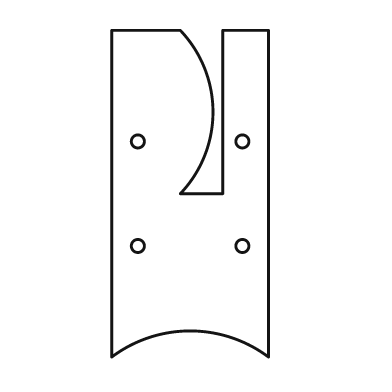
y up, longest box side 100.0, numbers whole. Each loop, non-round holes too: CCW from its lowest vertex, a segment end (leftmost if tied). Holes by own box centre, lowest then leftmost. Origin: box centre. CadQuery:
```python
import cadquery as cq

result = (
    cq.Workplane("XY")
    .moveTo(-24.0, -50.0)
    .threePointArc((0.0, -42.0), (24.0, -50.0))
    .lineTo(24.0, 50.0)
    .lineTo(10.0, 50.0)
    .lineTo(10.0, 0.0)
    .lineTo(-3.0, 0.0)
    .threePointArc((7.0, 25.0), (-3.0, 50.0))
    .lineTo(-24.0, 50.0)
    .close()
    .moveTo(-16.0, -16.0)
    .circle(2.0)
    .moveTo(16.0, -16.0)
    .circle(2.0)
    .moveTo(-16.0, 16.0)
    .circle(2.0)
    .moveTo(16.0, 16.0)
    .circle(2.0)
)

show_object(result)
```